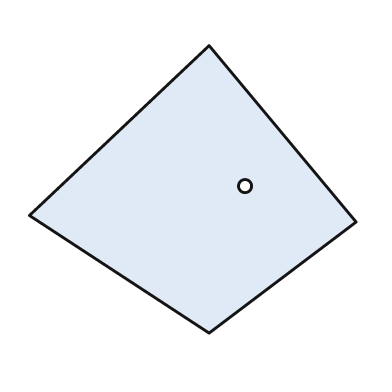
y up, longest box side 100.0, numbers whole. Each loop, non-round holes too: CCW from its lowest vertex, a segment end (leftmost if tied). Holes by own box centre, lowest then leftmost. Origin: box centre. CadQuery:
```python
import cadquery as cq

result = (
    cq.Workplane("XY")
    .moveTo(5.0, -44.0)
    .lineTo(50.0, -10.0)
    .lineTo(5.0, 44.0)
    .lineTo(-50.0, -8.0)
    .close()
    .moveTo(16.0, 1.0)
    .circle(2.0)
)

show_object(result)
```